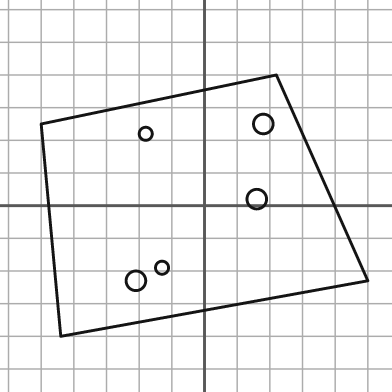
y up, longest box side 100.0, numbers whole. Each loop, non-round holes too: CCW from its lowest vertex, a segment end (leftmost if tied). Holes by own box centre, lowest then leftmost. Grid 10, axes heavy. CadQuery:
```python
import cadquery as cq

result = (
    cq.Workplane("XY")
    .moveTo(-44.0, -40.0)
    .lineTo(50.0, -23.0)
    .lineTo(22.0, 40.0)
    .lineTo(-50.0, 25.0)
    .close()
    .moveTo(-21.0, -23.0)
    .circle(3.0)
    .moveTo(-13.0, -19.0)
    .circle(2.0)
    .moveTo(16.0, 2.0)
    .circle(3.0)
    .moveTo(-18.0, 22.0)
    .circle(2.0)
    .moveTo(18.0, 25.0)
    .circle(3.0)
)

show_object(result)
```